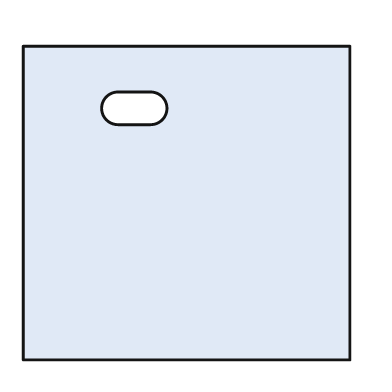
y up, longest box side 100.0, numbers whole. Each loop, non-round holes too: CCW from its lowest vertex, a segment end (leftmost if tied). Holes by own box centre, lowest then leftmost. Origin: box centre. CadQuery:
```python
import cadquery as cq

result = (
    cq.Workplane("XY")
    .moveTo(-50.0, -48.0)
    .lineTo(50.0, -48.0)
    .lineTo(50.0, 48.0)
    .lineTo(-50.0, 48.0)
    .close()
    .moveTo(-21.0, 24.0)
    .lineTo(-11.0, 24.0)
    .threePointArc((-6.0, 29.0), (-11.0, 34.0))
    .lineTo(-21.0, 34.0)
    .threePointArc((-26.0, 29.0), (-21.0, 24.0))
    .close()
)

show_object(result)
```